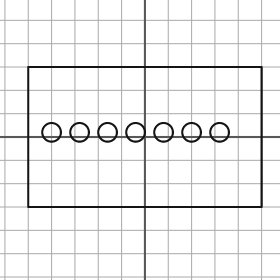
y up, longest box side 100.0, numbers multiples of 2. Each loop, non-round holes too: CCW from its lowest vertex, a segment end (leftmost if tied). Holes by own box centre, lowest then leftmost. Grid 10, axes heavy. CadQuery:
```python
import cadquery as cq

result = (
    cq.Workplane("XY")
    .moveTo(-50.0, -30.0)
    .lineTo(50.0, -30.0)
    .lineTo(50.0, 30.0)
    .lineTo(-50.0, 30.0)
    .close()
    .moveTo(-40.0, 2.0)
    .circle(4.0)
    .moveTo(-28.0, 2.0)
    .circle(4.0)
    .moveTo(-16.0, 2.0)
    .circle(4.0)
    .moveTo(-4.0, 2.0)
    .circle(4.0)
    .moveTo(8.0, 2.0)
    .circle(4.0)
    .moveTo(20.0, 2.0)
    .circle(4.0)
    .moveTo(32.0, 2.0)
    .circle(4.0)
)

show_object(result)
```